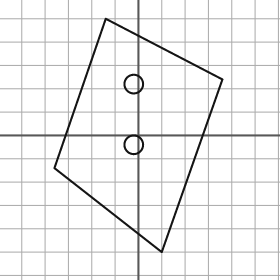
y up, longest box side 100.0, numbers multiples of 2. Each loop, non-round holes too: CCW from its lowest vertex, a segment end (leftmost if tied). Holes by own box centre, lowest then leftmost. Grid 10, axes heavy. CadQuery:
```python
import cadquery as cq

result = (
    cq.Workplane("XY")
    .moveTo(10.0, -50.0)
    .lineTo(36.0, 24.0)
    .lineTo(-14.0, 50.0)
    .lineTo(-36.0, -14.0)
    .close()
    .moveTo(-2.0, -4.0)
    .circle(4.0)
    .moveTo(-2.0, 22.0)
    .circle(4.0)
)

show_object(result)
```